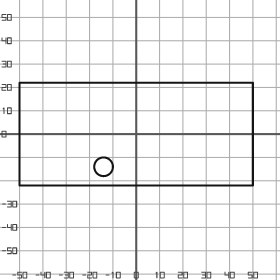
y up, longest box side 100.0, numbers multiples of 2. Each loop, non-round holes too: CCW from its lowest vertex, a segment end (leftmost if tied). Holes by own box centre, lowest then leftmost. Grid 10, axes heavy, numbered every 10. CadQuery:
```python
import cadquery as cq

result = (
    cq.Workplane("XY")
    .moveTo(-50.0, -22.0)
    .lineTo(50.0, -22.0)
    .lineTo(50.0, 22.0)
    .lineTo(-50.0, 22.0)
    .close()
    .moveTo(-14.0, -14.0)
    .circle(4.0)
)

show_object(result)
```